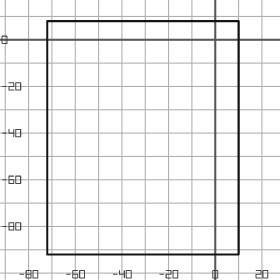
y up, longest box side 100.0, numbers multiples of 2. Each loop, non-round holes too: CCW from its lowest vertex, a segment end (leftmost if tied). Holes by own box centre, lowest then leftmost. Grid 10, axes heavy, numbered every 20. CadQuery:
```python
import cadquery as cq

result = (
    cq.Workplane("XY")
    .moveTo(-72.0, -92.0)
    .lineTo(10.0, -92.0)
    .lineTo(10.0, 8.0)
    .lineTo(-72.0, 8.0)
    .close()
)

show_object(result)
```